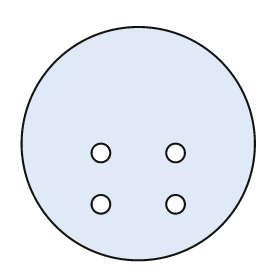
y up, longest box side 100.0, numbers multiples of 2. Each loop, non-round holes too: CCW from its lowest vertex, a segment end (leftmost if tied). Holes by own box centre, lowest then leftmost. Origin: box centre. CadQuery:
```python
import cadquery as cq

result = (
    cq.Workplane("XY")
    .moveTo(0.0, 0.0)
    .circle(50.0)
    .moveTo(-16.0, -26.0)
    .circle(4.0)
    .moveTo(16.0, -26.0)
    .circle(4.0)
    .moveTo(-16.0, -4.0)
    .circle(4.0)
    .moveTo(16.0, -4.0)
    .circle(4.0)
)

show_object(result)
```